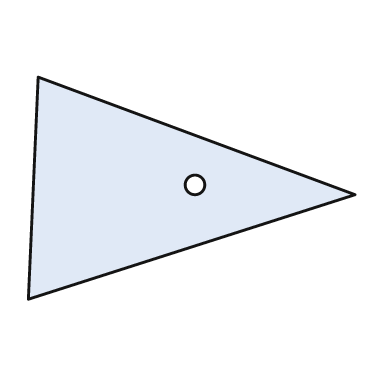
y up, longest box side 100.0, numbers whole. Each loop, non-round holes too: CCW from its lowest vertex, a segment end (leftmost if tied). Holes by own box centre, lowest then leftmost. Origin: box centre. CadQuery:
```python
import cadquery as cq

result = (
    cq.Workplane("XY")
    .moveTo(-50.0, -34.0)
    .lineTo(50.0, -2.0)
    .lineTo(-47.0, 34.0)
    .close()
    .moveTo(1.0, 1.0)
    .circle(3.0)
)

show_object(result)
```